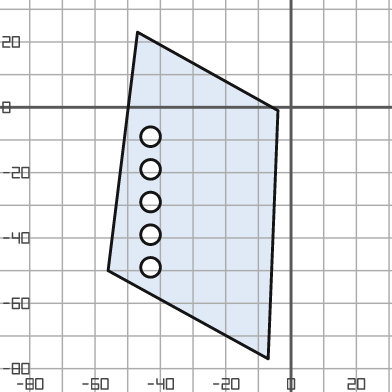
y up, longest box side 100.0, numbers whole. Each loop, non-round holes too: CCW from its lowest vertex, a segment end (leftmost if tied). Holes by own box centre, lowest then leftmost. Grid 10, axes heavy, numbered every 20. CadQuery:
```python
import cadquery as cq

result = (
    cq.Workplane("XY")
    .moveTo(-7.0, -77.0)
    .lineTo(-4.0, -1.0)
    .lineTo(-47.0, 23.0)
    .lineTo(-56.0, -50.0)
    .close()
    .moveTo(-43.0, -49.0)
    .circle(3.0)
    .moveTo(-43.0, -39.0)
    .circle(3.0)
    .moveTo(-43.0, -29.0)
    .circle(3.0)
    .moveTo(-43.0, -19.0)
    .circle(3.0)
    .moveTo(-43.0, -9.0)
    .circle(3.0)
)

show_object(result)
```